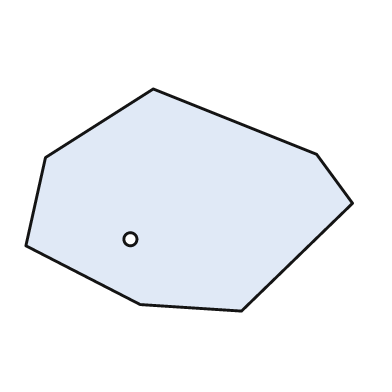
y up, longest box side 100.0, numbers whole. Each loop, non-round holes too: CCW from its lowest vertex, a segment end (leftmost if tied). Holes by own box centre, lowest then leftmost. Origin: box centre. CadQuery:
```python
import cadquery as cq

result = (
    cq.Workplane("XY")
    .moveTo(16.0, -34.0)
    .lineTo(50.0, -1.0)
    .lineTo(39.0, 14.0)
    .lineTo(-11.0, 34.0)
    .lineTo(-44.0, 13.0)
    .lineTo(-50.0, -14.0)
    .lineTo(-15.0, -32.0)
    .close()
    .moveTo(-18.0, -12.0)
    .circle(2.0)
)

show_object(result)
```